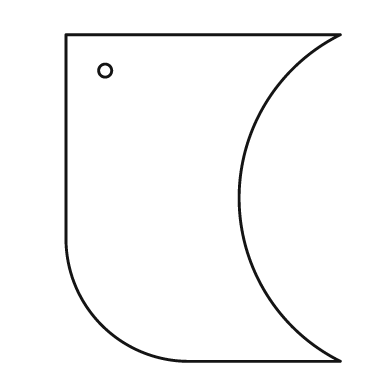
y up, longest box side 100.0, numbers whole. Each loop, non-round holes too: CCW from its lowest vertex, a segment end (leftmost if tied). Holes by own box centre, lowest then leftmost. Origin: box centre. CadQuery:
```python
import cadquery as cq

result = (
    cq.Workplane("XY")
    .moveTo(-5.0, -50.0)
    .lineTo(42.0, -50.0)
    .threePointArc((11.0, 0.0), (42.0, 50.0))
    .lineTo(-42.0, 50.0)
    .lineTo(-42.0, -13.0)
    .threePointArc((-31.0, -39.0), (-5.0, -50.0))
    .close()
    .moveTo(-30.0, 39.0)
    .circle(2.0)
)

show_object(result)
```